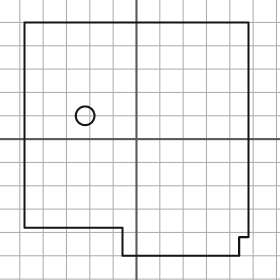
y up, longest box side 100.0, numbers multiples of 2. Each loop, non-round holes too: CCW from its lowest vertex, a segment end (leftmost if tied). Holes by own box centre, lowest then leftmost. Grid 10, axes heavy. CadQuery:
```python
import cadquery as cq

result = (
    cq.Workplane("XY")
    .moveTo(-6.0, -50.0)
    .lineTo(44.0, -50.0)
    .lineTo(44.0, -42.0)
    .lineTo(48.0, -42.0)
    .lineTo(48.0, 50.0)
    .lineTo(-48.0, 50.0)
    .lineTo(-48.0, -38.0)
    .lineTo(-6.0, -38.0)
    .close()
    .moveTo(-22.0, 10.0)
    .circle(4.0)
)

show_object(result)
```